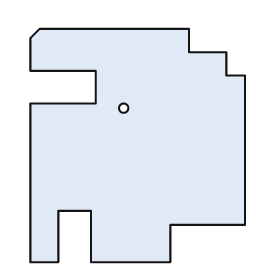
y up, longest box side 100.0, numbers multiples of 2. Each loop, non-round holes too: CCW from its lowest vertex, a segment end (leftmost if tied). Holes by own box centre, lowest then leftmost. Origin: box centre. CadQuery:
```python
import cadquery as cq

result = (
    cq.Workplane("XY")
    .moveTo(-46.0, -50.0)
    .lineTo(-34.0, -50.0)
    .lineTo(-34.0, -28.0)
    .lineTo(-20.0, -28.0)
    .lineTo(-20.0, -50.0)
    .lineTo(14.0, -50.0)
    .lineTo(14.0, -34.0)
    .lineTo(46.0, -34.0)
    .lineTo(46.0, 30.0)
    .lineTo(38.0, 30.0)
    .lineTo(38.0, 40.0)
    .lineTo(22.0, 40.0)
    .lineTo(22.0, 50.0)
    .lineTo(-42.0, 50.0)
    .lineTo(-46.0, 46.0)
    .lineTo(-46.0, 32.0)
    .lineTo(-18.0, 32.0)
    .lineTo(-18.0, 18.0)
    .lineTo(-46.0, 18.0)
    .close()
    .moveTo(-6.0, 16.0)
    .circle(2.0)
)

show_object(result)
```